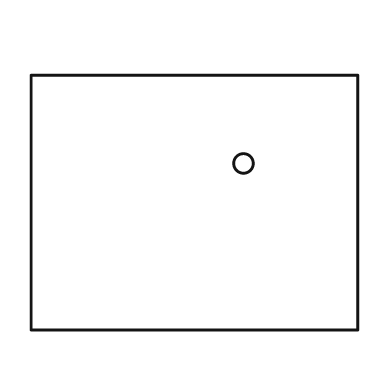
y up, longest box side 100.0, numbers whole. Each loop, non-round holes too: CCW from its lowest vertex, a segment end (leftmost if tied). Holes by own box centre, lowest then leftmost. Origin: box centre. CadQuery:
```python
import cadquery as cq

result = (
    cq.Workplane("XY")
    .moveTo(-50.0, -39.0)
    .lineTo(50.0, -39.0)
    .lineTo(50.0, 39.0)
    .lineTo(-50.0, 39.0)
    .close()
    .moveTo(15.0, 12.0)
    .circle(3.0)
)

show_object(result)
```